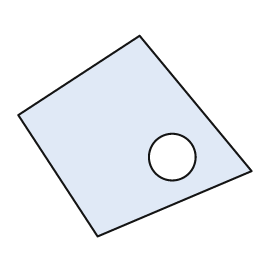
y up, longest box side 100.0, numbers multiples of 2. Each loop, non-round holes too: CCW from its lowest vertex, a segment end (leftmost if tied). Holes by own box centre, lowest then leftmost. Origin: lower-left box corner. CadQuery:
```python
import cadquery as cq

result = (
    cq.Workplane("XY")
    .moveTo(34.0, 0.0)
    .lineTo(100.0, 28.0)
    .lineTo(52.0, 86.0)
    .lineTo(0.0, 52.0)
    .close()
    .moveTo(66.0, 34.0)
    .circle(10.0)
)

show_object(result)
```